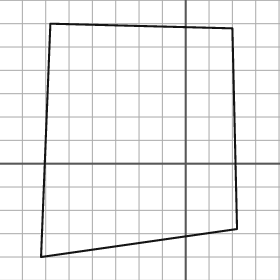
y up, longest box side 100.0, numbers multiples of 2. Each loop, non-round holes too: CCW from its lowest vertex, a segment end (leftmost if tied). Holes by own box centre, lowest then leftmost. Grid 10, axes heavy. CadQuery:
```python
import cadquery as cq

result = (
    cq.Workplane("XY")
    .moveTo(-62.0, -40.0)
    .lineTo(22.0, -28.0)
    .lineTo(20.0, 58.0)
    .lineTo(-58.0, 60.0)
    .close()
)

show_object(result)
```